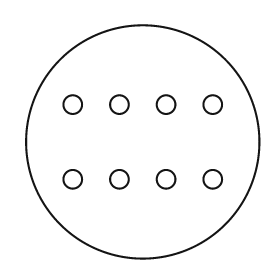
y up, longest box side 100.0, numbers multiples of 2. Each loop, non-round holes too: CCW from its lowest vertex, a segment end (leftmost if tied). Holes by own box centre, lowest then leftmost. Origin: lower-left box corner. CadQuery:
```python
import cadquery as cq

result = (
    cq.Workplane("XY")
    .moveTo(50.0, 50.0)
    .circle(50.0)
    .moveTo(20.0, 34.0)
    .circle(4.0)
    .moveTo(40.0, 34.0)
    .circle(4.0)
    .moveTo(60.0, 34.0)
    .circle(4.0)
    .moveTo(80.0, 34.0)
    .circle(4.0)
    .moveTo(20.0, 66.0)
    .circle(4.0)
    .moveTo(40.0, 66.0)
    .circle(4.0)
    .moveTo(60.0, 66.0)
    .circle(4.0)
    .moveTo(80.0, 66.0)
    .circle(4.0)
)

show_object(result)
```